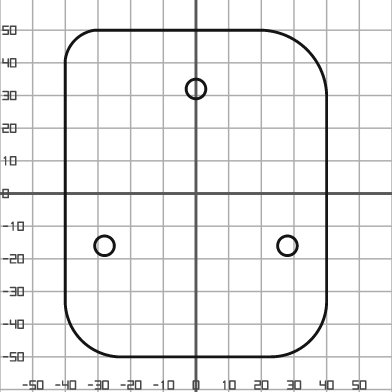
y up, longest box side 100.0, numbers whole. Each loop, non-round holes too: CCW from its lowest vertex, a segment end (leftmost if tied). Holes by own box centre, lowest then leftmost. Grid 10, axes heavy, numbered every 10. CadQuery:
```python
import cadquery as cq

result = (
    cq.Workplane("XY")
    .moveTo(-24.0, -50.0)
    .lineTo(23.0, -50.0)
    .threePointArc((35.0, -45.0), (40.0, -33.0))
    .lineTo(40.0, 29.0)
    .threePointArc((34.0, 44.0), (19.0, 50.0))
    .lineTo(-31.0, 50.0)
    .threePointArc((-37.0, 47.0), (-40.0, 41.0))
    .lineTo(-40.0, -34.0)
    .threePointArc((-35.0, -45.0), (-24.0, -50.0))
    .close()
    .moveTo(-28.0, -16.0)
    .circle(3.0)
    .moveTo(28.0, -16.0)
    .circle(3.0)
    .moveTo(0.0, 32.0)
    .circle(3.0)
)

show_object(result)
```